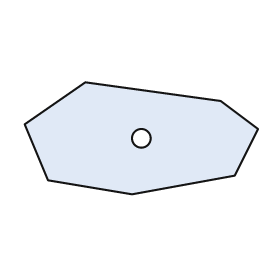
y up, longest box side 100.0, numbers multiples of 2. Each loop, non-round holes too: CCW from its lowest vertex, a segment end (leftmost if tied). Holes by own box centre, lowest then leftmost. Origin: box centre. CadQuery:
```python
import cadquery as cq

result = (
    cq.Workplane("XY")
    .moveTo(-4.0, -24.0)
    .lineTo(40.0, -16.0)
    .lineTo(50.0, 4.0)
    .lineTo(34.0, 16.0)
    .lineTo(-24.0, 24.0)
    .lineTo(-50.0, 6.0)
    .lineTo(-40.0, -18.0)
    .close()
    .moveTo(0.0, 0.0)
    .circle(4.0)
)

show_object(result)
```